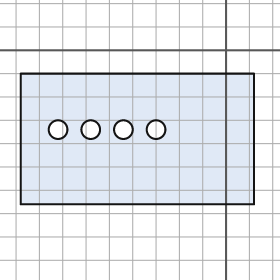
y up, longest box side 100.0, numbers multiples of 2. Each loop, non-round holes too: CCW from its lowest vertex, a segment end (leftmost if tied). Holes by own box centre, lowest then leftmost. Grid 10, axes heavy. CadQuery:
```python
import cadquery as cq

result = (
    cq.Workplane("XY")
    .moveTo(-88.0, -66.0)
    .lineTo(12.0, -66.0)
    .lineTo(12.0, -10.0)
    .lineTo(-88.0, -10.0)
    .close()
    .moveTo(-72.0, -34.0)
    .circle(4.0)
    .moveTo(-58.0, -34.0)
    .circle(4.0)
    .moveTo(-44.0, -34.0)
    .circle(4.0)
    .moveTo(-30.0, -34.0)
    .circle(4.0)
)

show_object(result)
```